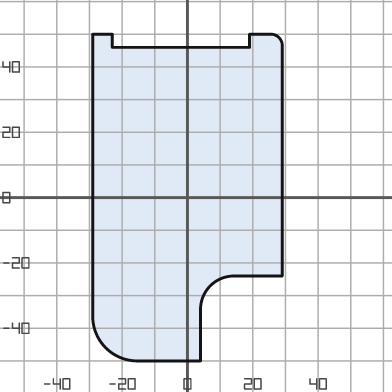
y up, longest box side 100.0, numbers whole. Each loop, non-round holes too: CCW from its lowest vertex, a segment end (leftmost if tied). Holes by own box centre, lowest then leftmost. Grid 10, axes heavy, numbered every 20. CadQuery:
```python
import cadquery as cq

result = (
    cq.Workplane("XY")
    .moveTo(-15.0, -50.0)
    .lineTo(4.0, -50.0)
    .lineTo(4.0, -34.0)
    .threePointArc((7.0, -27.0), (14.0, -24.0))
    .lineTo(29.0, -24.0)
    .lineTo(29.0, 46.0)
    .threePointArc((28.0, 49.0), (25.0, 50.0))
    .lineTo(19.0, 50.0)
    .lineTo(19.0, 46.0)
    .lineTo(-23.0, 46.0)
    .lineTo(-23.0, 50.0)
    .lineTo(-29.0, 50.0)
    .lineTo(-29.0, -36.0)
    .threePointArc((-25.0, -46.0), (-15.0, -50.0))
    .close()
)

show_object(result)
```